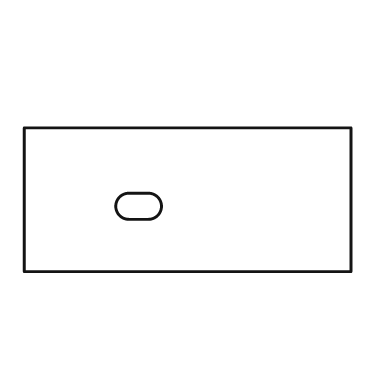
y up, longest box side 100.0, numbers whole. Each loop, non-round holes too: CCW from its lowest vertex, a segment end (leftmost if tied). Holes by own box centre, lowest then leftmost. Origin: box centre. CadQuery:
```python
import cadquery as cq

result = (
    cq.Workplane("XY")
    .moveTo(-50.0, -22.0)
    .lineTo(50.0, -22.0)
    .lineTo(50.0, 22.0)
    .lineTo(-50.0, 22.0)
    .close()
    .moveTo(-18.0, -6.0)
    .lineTo(-12.0, -6.0)
    .threePointArc((-8.0, -2.0), (-12.0, 2.0))
    .lineTo(-18.0, 2.0)
    .threePointArc((-22.0, -2.0), (-18.0, -6.0))
    .close()
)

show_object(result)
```